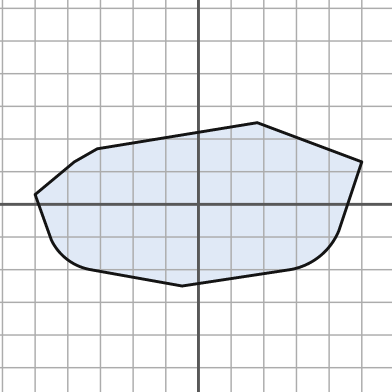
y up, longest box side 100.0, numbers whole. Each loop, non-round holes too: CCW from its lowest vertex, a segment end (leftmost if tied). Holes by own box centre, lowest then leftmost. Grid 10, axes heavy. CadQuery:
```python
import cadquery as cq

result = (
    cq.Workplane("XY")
    .moveTo(-5.0, -25.0)
    .lineTo(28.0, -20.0)
    .threePointArc((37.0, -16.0), (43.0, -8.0))
    .lineTo(50.0, 13.0)
    .lineTo(18.0, 25.0)
    .lineTo(-31.0, 17.0)
    .lineTo(-38.0, 13.0)
    .lineTo(-50.0, 3.0)
    .lineTo(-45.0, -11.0)
    .threePointArc((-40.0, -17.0), (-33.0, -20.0))
    .close()
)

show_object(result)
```